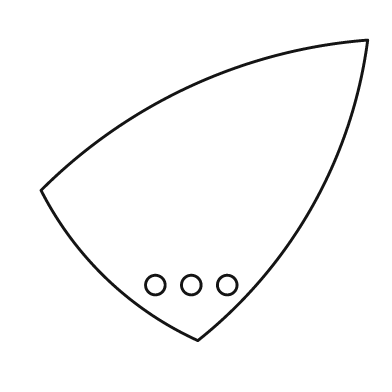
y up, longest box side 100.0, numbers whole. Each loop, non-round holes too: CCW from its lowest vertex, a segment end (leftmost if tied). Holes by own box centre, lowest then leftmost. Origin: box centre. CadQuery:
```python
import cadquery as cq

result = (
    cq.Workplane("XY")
    .moveTo(-2.0, -46.0)
    .threePointArc((33.0, -5.0), (50.0, 46.0))
    .threePointArc((-4.0, 32.0), (-50.0, 0.0))
    .threePointArc((-30.0, -27.0), (-2.0, -46.0))
    .close()
    .moveTo(-15.0, -29.0)
    .circle(3.0)
    .moveTo(-4.0, -29.0)
    .circle(3.0)
    .moveTo(7.0, -29.0)
    .circle(3.0)
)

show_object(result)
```